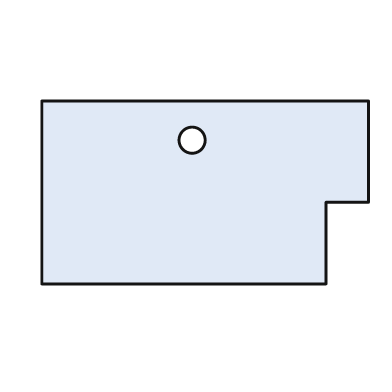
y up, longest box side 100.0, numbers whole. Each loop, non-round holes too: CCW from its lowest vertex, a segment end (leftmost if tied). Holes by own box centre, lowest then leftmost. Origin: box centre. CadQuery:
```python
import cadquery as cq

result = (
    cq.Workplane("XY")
    .moveTo(-50.0, -28.0)
    .lineTo(37.0, -28.0)
    .lineTo(37.0, -3.0)
    .lineTo(50.0, -3.0)
    .lineTo(50.0, 28.0)
    .lineTo(-50.0, 28.0)
    .close()
    .moveTo(-4.0, 16.0)
    .circle(4.0)
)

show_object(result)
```